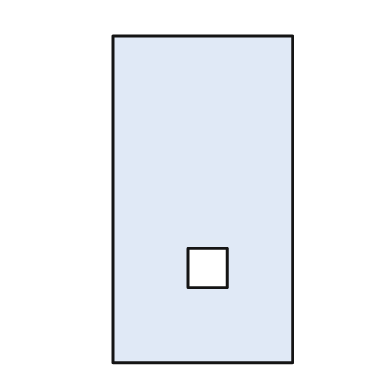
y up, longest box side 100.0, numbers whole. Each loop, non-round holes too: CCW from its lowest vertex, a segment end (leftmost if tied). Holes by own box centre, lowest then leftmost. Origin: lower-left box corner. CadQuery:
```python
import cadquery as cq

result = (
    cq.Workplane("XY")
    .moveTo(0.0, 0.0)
    .lineTo(55.0, 0.0)
    .lineTo(55.0, 100.0)
    .lineTo(0.0, 100.0)
    .close()
    .moveTo(23.0, 23.0)
    .lineTo(35.0, 23.0)
    .lineTo(35.0, 35.0)
    .lineTo(23.0, 35.0)
    .close()
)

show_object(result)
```